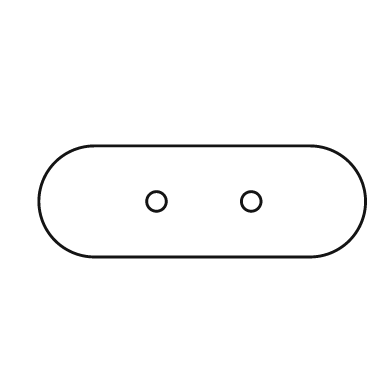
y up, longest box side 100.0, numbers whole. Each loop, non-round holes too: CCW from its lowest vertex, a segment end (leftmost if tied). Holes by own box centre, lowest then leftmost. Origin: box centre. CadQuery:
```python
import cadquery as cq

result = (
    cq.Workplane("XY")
    .moveTo(-33.0, -17.0)
    .lineTo(33.0, -17.0)
    .threePointArc((50.0, 0.0), (33.0, 17.0))
    .lineTo(-33.0, 17.0)
    .threePointArc((-50.0, 0.0), (-33.0, -17.0))
    .close()
    .moveTo(-14.0, 0.0)
    .circle(3.0)
    .moveTo(15.0, 0.0)
    .circle(3.0)
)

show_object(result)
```